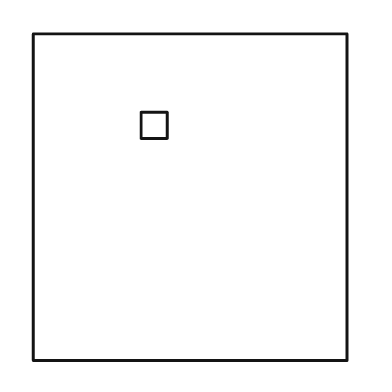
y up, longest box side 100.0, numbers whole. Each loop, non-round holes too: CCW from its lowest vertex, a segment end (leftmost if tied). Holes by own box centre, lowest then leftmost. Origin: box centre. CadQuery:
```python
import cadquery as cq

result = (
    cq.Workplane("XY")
    .moveTo(-48.0, -50.0)
    .lineTo(48.0, -50.0)
    .lineTo(48.0, 50.0)
    .lineTo(-48.0, 50.0)
    .close()
    .moveTo(-15.0, 18.0)
    .lineTo(-7.0, 18.0)
    .lineTo(-7.0, 26.0)
    .lineTo(-15.0, 26.0)
    .close()
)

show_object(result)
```